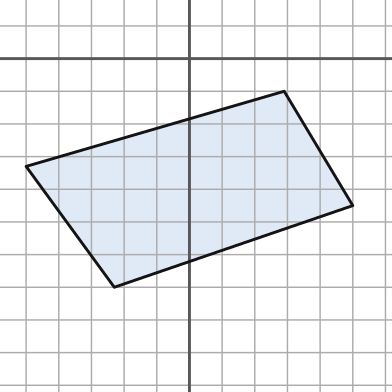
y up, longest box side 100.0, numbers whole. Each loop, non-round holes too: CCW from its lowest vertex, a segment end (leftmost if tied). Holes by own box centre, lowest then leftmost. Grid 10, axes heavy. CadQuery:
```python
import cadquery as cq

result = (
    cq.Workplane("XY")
    .moveTo(-23.0, -70.0)
    .lineTo(50.0, -45.0)
    .lineTo(29.0, -10.0)
    .lineTo(-50.0, -33.0)
    .close()
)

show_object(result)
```